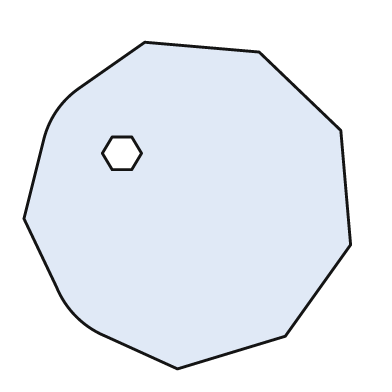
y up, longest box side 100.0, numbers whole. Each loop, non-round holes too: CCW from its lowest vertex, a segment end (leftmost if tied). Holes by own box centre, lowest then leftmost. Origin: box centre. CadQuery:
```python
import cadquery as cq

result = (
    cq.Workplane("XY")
    .moveTo(-3.0, -50.0)
    .lineTo(30.0, -40.0)
    .lineTo(50.0, -12.0)
    .lineTo(47.0, 23.0)
    .lineTo(22.0, 47.0)
    .lineTo(-13.0, 50.0)
    .lineTo(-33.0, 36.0)
    .threePointArc((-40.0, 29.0), (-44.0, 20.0))
    .lineTo(-50.0, -4.0)
    .lineTo(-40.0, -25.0)
    .threePointArc((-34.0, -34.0), (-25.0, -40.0))
    .close()
    .moveTo(-23.0, 11.0)
    .lineTo(-17.0, 11.0)
    .lineTo(-14.0, 16.0)
    .lineTo(-17.0, 21.0)
    .lineTo(-23.0, 21.0)
    .lineTo(-26.0, 16.0)
    .close()
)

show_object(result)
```